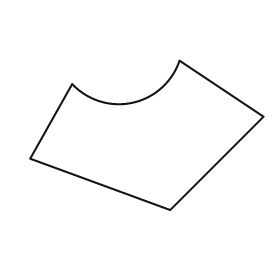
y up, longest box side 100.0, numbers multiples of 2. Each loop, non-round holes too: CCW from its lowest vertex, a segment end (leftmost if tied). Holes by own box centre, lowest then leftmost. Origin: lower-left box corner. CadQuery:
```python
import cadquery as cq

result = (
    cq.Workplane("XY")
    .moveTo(60.0, 0.0)
    .lineTo(100.0, 40.0)
    .lineTo(64.0, 64.0)
    .threePointArc((44.0, 46.0), (18.0, 54.0))
    .lineTo(0.0, 22.0)
    .close()
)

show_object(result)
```